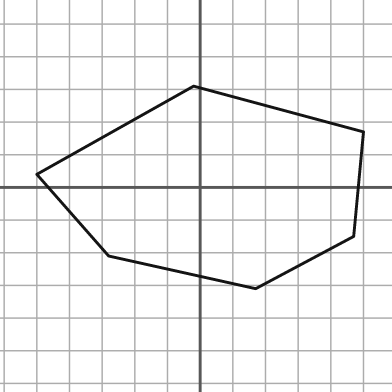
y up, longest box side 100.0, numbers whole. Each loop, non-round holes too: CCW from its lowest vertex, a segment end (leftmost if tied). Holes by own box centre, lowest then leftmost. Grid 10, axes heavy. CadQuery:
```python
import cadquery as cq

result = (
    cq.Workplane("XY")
    .moveTo(17.0, -31.0)
    .lineTo(47.0, -15.0)
    .lineTo(50.0, 17.0)
    .lineTo(-2.0, 31.0)
    .lineTo(-50.0, 4.0)
    .lineTo(-28.0, -21.0)
    .close()
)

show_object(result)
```